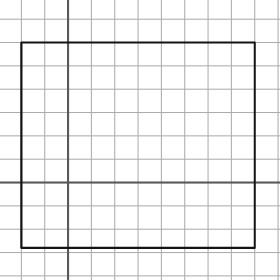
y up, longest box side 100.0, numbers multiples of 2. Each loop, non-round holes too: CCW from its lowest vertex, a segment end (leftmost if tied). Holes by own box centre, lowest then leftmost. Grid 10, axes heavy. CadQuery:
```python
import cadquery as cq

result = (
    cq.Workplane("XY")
    .moveTo(-20.0, -28.0)
    .lineTo(80.0, -28.0)
    .lineTo(80.0, 60.0)
    .lineTo(-20.0, 60.0)
    .close()
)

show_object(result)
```